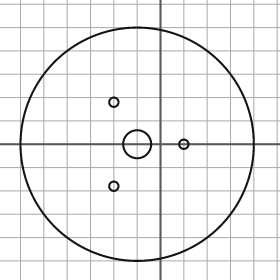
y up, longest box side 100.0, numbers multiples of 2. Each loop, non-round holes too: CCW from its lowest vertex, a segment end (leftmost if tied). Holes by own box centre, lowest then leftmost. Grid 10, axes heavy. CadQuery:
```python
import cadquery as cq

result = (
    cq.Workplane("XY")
    .moveTo(-10.0, 0.0)
    .circle(50.0)
    .moveTo(-20.0, -18.0)
    .circle(2.0)
    .moveTo(-10.0, 0.0)
    .circle(6.0)
    .moveTo(10.0, 0.0)
    .circle(2.0)
    .moveTo(-20.0, 18.0)
    .circle(2.0)
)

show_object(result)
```